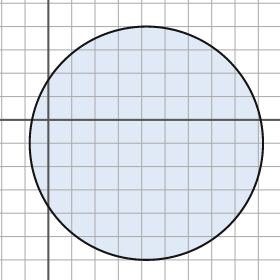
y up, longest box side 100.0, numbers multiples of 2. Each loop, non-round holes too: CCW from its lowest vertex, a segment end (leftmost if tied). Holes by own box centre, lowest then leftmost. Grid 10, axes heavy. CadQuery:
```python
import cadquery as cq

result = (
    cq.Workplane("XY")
    .moveTo(42.0, -10.0)
    .circle(50.0)
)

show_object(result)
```